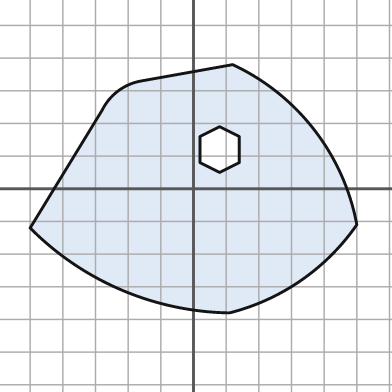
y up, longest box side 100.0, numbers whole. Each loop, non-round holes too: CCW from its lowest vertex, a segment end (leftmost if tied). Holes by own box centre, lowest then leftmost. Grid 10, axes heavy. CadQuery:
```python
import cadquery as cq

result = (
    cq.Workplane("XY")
    .moveTo(11.0, -38.0)
    .threePointArc((33.0, -28.0), (50.0, -11.0))
    .threePointArc((37.0, 18.0), (12.0, 38.0))
    .lineTo(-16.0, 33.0)
    .threePointArc((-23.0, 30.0), (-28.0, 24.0))
    .lineTo(-50.0, -12.0)
    .threePointArc((-22.0, -31.0), (11.0, -38.0))
    .close()
    .moveTo(8.0, 5.0)
    .lineTo(14.0, 8.0)
    .lineTo(14.0, 16.0)
    .lineTo(8.0, 19.0)
    .lineTo(2.0, 16.0)
    .lineTo(2.0, 8.0)
    .close()
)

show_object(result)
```